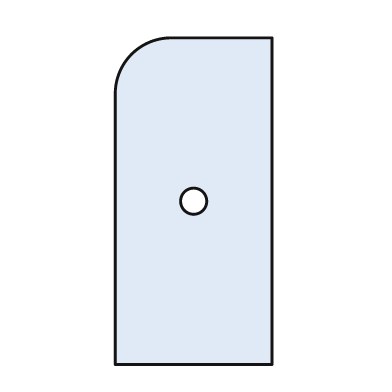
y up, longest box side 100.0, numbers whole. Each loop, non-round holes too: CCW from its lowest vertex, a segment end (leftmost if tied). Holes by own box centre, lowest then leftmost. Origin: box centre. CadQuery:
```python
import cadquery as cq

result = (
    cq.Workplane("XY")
    .moveTo(-24.0, -50.0)
    .lineTo(24.0, -50.0)
    .lineTo(24.0, 50.0)
    .lineTo(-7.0, 50.0)
    .threePointArc((-19.0, 45.0), (-24.0, 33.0))
    .close()
    .moveTo(0.0, 0.0)
    .circle(4.0)
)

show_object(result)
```